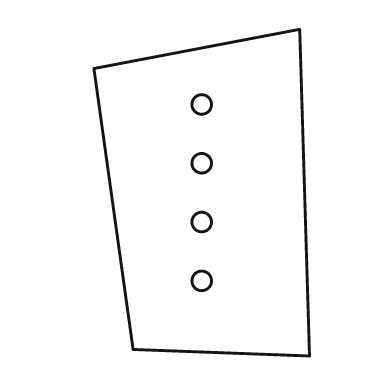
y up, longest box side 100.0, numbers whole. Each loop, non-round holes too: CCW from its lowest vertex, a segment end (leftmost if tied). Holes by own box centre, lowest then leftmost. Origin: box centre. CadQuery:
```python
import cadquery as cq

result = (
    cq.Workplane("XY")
    .moveTo(33.0, -50.0)
    .lineTo(30.0, 50.0)
    .lineTo(-33.0, 38.0)
    .lineTo(-21.0, -48.0)
    .close()
    .moveTo(0.0, -27.0)
    .circle(3.0)
    .moveTo(0.0, -9.0)
    .circle(3.0)
    .moveTo(0.0, 9.0)
    .circle(3.0)
    .moveTo(0.0, 27.0)
    .circle(3.0)
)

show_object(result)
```